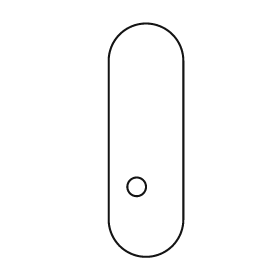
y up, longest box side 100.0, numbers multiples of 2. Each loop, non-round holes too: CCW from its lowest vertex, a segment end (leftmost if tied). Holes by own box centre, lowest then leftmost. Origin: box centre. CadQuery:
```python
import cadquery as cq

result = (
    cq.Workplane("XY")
    .moveTo(-16.0, -34.0)
    .threePointArc((0.0, -50.0), (16.0, -34.0))
    .lineTo(16.0, 34.0)
    .threePointArc((0.0, 50.0), (-16.0, 34.0))
    .close()
    .moveTo(-4.0, -20.0)
    .circle(4.0)
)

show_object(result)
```